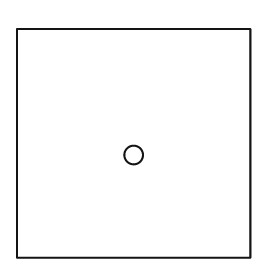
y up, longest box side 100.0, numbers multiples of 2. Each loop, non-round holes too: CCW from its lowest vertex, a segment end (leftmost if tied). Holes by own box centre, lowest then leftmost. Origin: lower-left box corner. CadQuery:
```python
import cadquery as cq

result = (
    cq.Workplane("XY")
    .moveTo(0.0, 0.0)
    .lineTo(100.0, 0.0)
    .lineTo(100.0, 98.0)
    .lineTo(0.0, 98.0)
    .close()
    .moveTo(50.0, 44.0)
    .circle(4.0)
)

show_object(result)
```